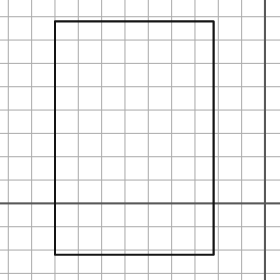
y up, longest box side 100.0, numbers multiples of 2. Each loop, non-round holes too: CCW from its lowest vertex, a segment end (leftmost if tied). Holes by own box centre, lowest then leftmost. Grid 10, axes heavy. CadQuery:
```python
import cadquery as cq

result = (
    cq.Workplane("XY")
    .moveTo(-90.0, -22.0)
    .lineTo(-22.0, -22.0)
    .lineTo(-22.0, 78.0)
    .lineTo(-90.0, 78.0)
    .close()
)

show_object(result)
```